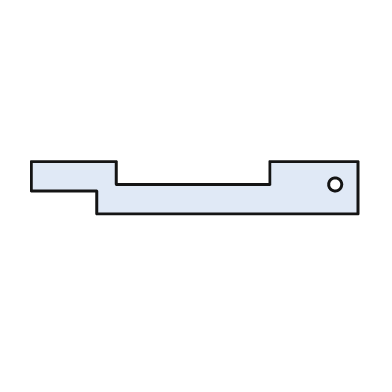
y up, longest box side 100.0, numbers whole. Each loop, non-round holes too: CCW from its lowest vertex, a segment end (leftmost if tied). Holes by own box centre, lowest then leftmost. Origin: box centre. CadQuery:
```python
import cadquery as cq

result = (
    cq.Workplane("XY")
    .moveTo(-30.0, -8.0)
    .lineTo(50.0, -8.0)
    .lineTo(50.0, 8.0)
    .lineTo(23.0, 8.0)
    .lineTo(23.0, 1.0)
    .lineTo(-24.0, 1.0)
    .lineTo(-24.0, 8.0)
    .lineTo(-50.0, 8.0)
    .lineTo(-50.0, -1.0)
    .lineTo(-30.0, -1.0)
    .close()
    .moveTo(43.0, 1.0)
    .circle(2.0)
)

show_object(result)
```